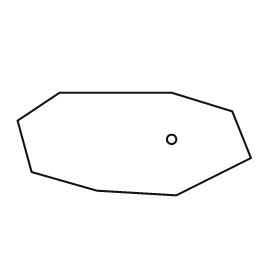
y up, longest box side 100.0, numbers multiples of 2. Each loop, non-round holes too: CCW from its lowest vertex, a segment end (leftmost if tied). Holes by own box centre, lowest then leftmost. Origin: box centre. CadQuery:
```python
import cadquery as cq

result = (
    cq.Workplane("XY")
    .moveTo(18.0, -22.0)
    .lineTo(50.0, -6.0)
    .lineTo(42.0, 14.0)
    .lineTo(16.0, 22.0)
    .lineTo(-32.0, 22.0)
    .lineTo(-50.0, 10.0)
    .lineTo(-44.0, -12.0)
    .lineTo(-16.0, -20.0)
    .close()
    .moveTo(16.0, 2.0)
    .circle(2.0)
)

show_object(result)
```